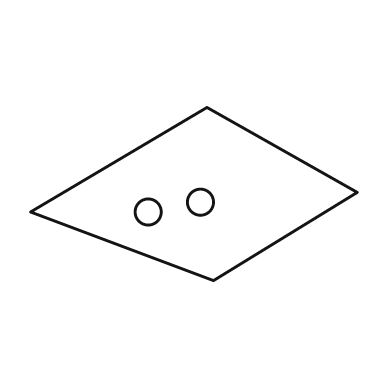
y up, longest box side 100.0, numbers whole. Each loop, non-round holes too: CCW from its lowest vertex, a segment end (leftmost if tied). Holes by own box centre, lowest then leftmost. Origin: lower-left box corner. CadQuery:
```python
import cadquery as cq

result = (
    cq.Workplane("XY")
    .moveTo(56.0, 0.0)
    .lineTo(100.0, 27.0)
    .lineTo(54.0, 53.0)
    .lineTo(0.0, 21.0)
    .close()
    .moveTo(36.0, 21.0)
    .circle(4.0)
    .moveTo(52.0, 24.0)
    .circle(4.0)
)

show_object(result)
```